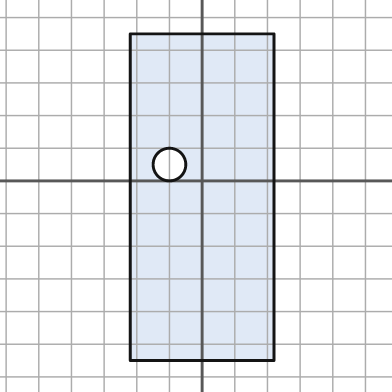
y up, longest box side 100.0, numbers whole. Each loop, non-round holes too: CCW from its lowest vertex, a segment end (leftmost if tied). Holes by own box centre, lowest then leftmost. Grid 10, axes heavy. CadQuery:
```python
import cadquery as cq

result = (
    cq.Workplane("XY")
    .moveTo(-22.0, -55.0)
    .lineTo(22.0, -55.0)
    .lineTo(22.0, 45.0)
    .lineTo(-22.0, 45.0)
    .close()
    .moveTo(-10.0, 5.0)
    .circle(5.0)
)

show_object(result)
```